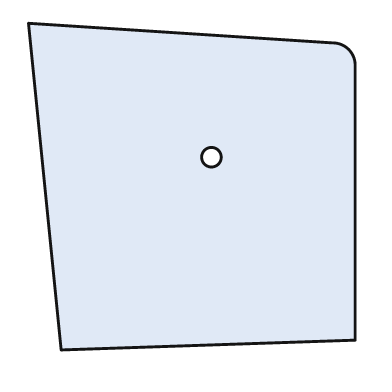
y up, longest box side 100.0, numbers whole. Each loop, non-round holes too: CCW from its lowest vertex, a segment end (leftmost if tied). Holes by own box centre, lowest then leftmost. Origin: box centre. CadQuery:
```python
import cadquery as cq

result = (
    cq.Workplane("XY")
    .moveTo(-40.0, -50.0)
    .lineTo(50.0, -47.0)
    .lineTo(50.0, 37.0)
    .threePointArc((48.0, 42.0), (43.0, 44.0))
    .lineTo(-50.0, 50.0)
    .close()
    .moveTo(6.0, 9.0)
    .circle(3.0)
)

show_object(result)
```